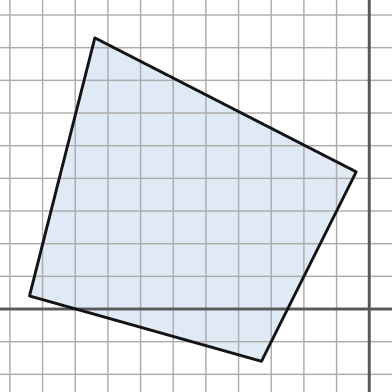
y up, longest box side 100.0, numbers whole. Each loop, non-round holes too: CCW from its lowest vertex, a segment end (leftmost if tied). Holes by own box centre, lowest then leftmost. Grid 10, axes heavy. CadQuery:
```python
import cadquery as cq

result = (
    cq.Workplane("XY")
    .moveTo(-33.0, -16.0)
    .lineTo(-4.0, 42.0)
    .lineTo(-84.0, 83.0)
    .lineTo(-104.0, 4.0)
    .close()
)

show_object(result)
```